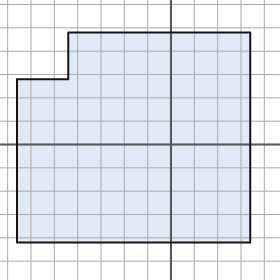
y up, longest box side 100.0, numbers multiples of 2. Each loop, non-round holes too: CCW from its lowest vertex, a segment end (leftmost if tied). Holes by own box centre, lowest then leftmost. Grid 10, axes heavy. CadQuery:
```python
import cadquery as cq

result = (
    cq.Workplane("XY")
    .moveTo(-66.0, -42.0)
    .lineTo(34.0, -42.0)
    .lineTo(34.0, 48.0)
    .lineTo(-44.0, 48.0)
    .lineTo(-44.0, 28.0)
    .lineTo(-66.0, 28.0)
    .close()
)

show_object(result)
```